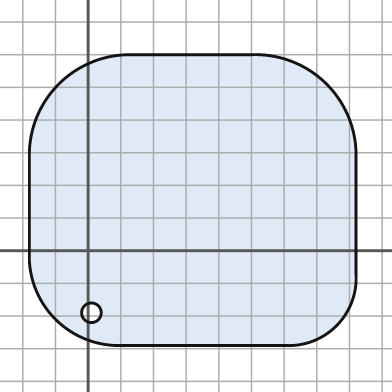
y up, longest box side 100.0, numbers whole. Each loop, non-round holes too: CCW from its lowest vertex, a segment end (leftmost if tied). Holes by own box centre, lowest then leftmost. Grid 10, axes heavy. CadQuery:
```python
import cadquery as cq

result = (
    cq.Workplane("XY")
    .moveTo(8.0, -29.0)
    .lineTo(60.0, -29.0)
    .threePointArc((76.0, -23.0), (82.0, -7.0))
    .lineTo(82.0, 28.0)
    .threePointArc((73.0, 51.0), (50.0, 60.0))
    .lineTo(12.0, 60.0)
    .threePointArc((-9.0, 51.0), (-18.0, 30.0))
    .lineTo(-18.0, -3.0)
    .threePointArc((-10.0, -21.0), (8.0, -29.0))
    .close()
    .moveTo(1.0, -19.0)
    .circle(3.0)
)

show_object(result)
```